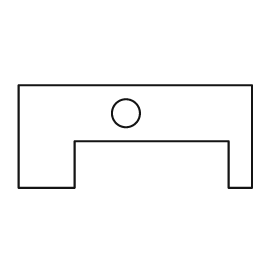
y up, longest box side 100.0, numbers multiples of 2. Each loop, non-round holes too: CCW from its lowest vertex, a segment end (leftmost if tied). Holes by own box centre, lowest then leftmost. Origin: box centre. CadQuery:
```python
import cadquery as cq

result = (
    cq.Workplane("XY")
    .moveTo(-50.0, -22.0)
    .lineTo(-26.0, -22.0)
    .lineTo(-26.0, -2.0)
    .lineTo(40.0, -2.0)
    .lineTo(40.0, -22.0)
    .lineTo(50.0, -22.0)
    .lineTo(50.0, 22.0)
    .lineTo(-50.0, 22.0)
    .close()
    .moveTo(-4.0, 10.0)
    .circle(6.0)
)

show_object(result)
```